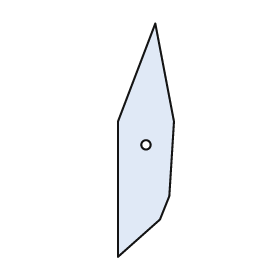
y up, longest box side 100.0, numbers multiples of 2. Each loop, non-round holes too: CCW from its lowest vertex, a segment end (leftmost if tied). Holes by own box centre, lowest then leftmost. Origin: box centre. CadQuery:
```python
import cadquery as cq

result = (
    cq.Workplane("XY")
    .moveTo(-12.0, -50.0)
    .lineTo(6.0, -34.0)
    .lineTo(10.0, -24.0)
    .lineTo(12.0, 8.0)
    .lineTo(4.0, 50.0)
    .lineTo(-12.0, 8.0)
    .close()
    .moveTo(0.0, -2.0)
    .circle(2.0)
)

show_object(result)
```